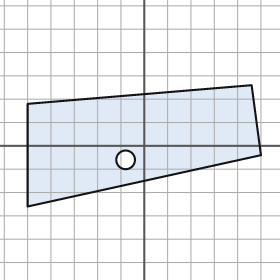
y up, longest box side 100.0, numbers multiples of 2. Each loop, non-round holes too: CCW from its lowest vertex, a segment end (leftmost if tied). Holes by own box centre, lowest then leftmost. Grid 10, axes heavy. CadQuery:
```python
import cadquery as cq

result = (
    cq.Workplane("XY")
    .moveTo(-50.0, -26.0)
    .lineTo(50.0, -4.0)
    .lineTo(46.0, 26.0)
    .lineTo(-50.0, 18.0)
    .close()
    .moveTo(-8.0, -6.0)
    .circle(4.0)
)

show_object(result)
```